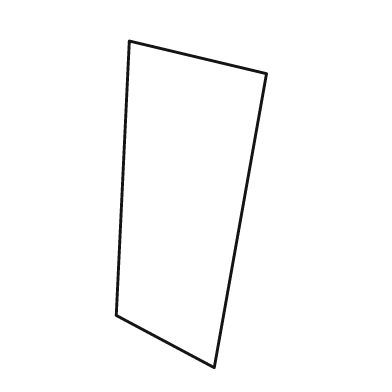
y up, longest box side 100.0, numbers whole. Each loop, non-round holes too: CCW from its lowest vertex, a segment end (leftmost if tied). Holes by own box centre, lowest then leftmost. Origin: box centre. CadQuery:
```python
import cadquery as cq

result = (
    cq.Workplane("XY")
    .moveTo(7.0, -50.0)
    .lineTo(23.0, 40.0)
    .lineTo(-19.0, 50.0)
    .lineTo(-23.0, -34.0)
    .close()
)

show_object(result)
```